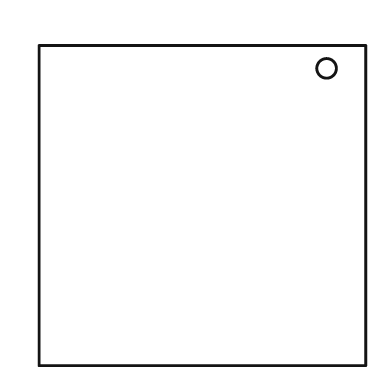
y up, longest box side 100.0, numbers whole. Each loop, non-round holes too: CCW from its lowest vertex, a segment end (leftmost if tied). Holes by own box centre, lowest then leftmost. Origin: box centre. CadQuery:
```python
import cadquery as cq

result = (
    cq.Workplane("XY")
    .moveTo(-50.0, -49.0)
    .lineTo(50.0, -49.0)
    .lineTo(50.0, 49.0)
    .lineTo(-50.0, 49.0)
    .close()
    .moveTo(38.0, 42.0)
    .circle(3.0)
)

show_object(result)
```